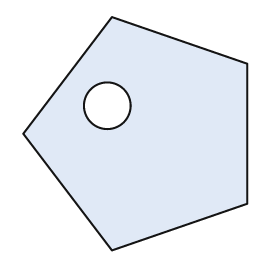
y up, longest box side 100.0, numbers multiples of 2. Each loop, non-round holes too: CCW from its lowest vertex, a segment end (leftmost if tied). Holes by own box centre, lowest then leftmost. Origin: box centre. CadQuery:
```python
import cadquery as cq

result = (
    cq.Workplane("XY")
    .moveTo(-10.0, -50.0)
    .lineTo(48.0, -30.0)
    .lineTo(48.0, 30.0)
    .lineTo(-10.0, 50.0)
    .lineTo(-48.0, 0.0)
    .close()
    .moveTo(-12.0, 12.0)
    .circle(10.0)
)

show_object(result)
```